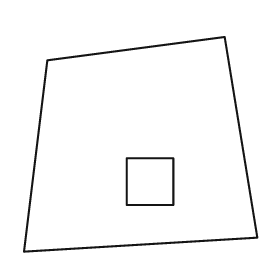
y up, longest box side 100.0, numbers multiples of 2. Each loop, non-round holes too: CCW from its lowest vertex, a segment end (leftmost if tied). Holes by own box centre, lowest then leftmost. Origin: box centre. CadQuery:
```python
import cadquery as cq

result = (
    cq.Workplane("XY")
    .moveTo(-50.0, -46.0)
    .lineTo(50.0, -40.0)
    .lineTo(36.0, 46.0)
    .lineTo(-40.0, 36.0)
    .close()
    .moveTo(-6.0, -26.0)
    .lineTo(14.0, -26.0)
    .lineTo(14.0, -6.0)
    .lineTo(-6.0, -6.0)
    .close()
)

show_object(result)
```